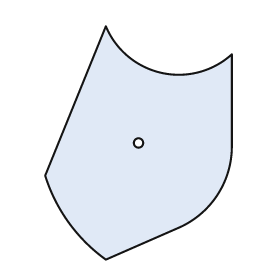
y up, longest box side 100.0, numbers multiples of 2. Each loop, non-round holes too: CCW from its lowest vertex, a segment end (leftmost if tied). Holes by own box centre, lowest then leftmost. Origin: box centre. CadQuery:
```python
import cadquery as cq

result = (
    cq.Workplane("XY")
    .moveTo(-14.0, -50.0)
    .lineTo(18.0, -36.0)
    .threePointArc((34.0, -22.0), (40.0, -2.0))
    .lineTo(40.0, 38.0)
    .threePointArc((10.0, 30.0), (-14.0, 50.0))
    .lineTo(-40.0, -14.0)
    .threePointArc((-30.0, -34.0), (-14.0, -50.0))
    .close()
    .moveTo(0.0, 0.0)
    .circle(2.0)
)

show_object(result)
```